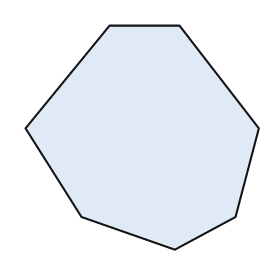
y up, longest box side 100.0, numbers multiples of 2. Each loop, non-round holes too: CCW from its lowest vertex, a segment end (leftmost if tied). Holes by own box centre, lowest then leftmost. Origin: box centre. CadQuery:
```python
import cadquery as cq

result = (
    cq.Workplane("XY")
    .moveTo(14.0, -48.0)
    .lineTo(40.0, -34.0)
    .lineTo(50.0, 4.0)
    .lineTo(16.0, 48.0)
    .lineTo(-14.0, 48.0)
    .lineTo(-50.0, 4.0)
    .lineTo(-26.0, -34.0)
    .close()
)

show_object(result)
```